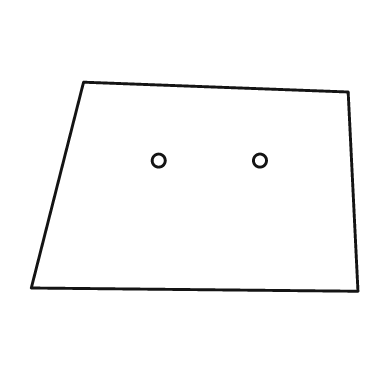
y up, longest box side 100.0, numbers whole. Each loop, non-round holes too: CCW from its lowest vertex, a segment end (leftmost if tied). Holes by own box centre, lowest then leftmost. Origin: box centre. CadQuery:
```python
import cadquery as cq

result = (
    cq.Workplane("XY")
    .moveTo(50.0, -32.0)
    .lineTo(47.0, 29.0)
    .lineTo(-34.0, 32.0)
    .lineTo(-50.0, -31.0)
    .close()
    .moveTo(-11.0, 8.0)
    .circle(2.0)
    .moveTo(20.0, 8.0)
    .circle(2.0)
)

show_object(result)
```